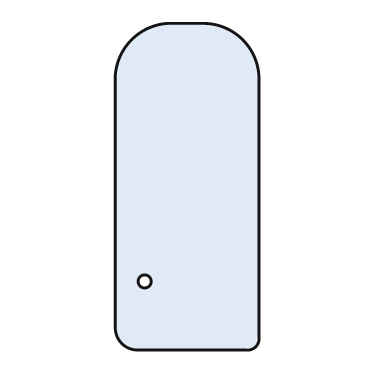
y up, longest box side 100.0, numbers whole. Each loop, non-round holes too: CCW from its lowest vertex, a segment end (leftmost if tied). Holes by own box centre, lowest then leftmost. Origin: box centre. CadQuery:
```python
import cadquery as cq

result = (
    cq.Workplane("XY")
    .moveTo(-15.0, -50.0)
    .lineTo(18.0, -50.0)
    .threePointArc((21.0, -49.0), (22.0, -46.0))
    .lineTo(22.0, 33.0)
    .threePointArc((17.0, 45.0), (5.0, 50.0))
    .lineTo(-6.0, 50.0)
    .threePointArc((-17.0, 45.0), (-22.0, 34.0))
    .lineTo(-22.0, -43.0)
    .threePointArc((-20.0, -48.0), (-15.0, -50.0))
    .close()
    .moveTo(-13.0, -29.0)
    .circle(2.0)
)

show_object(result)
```